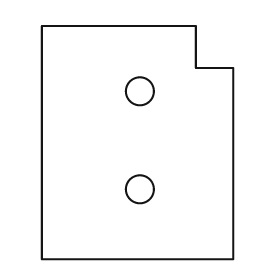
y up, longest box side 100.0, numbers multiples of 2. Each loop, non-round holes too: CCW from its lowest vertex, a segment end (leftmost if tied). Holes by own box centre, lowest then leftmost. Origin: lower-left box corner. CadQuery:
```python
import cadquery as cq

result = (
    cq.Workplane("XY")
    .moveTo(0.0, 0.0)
    .lineTo(82.0, 0.0)
    .lineTo(82.0, 82.0)
    .lineTo(66.0, 82.0)
    .lineTo(66.0, 100.0)
    .lineTo(0.0, 100.0)
    .close()
    .moveTo(42.0, 30.0)
    .circle(6.0)
    .moveTo(42.0, 72.0)
    .circle(6.0)
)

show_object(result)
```